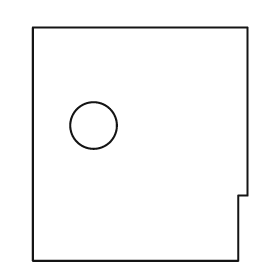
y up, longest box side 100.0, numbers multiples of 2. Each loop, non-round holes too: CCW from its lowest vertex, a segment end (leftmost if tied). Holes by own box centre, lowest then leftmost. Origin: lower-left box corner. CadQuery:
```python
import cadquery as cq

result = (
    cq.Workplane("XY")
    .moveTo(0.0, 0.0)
    .lineTo(88.0, 0.0)
    .lineTo(88.0, 28.0)
    .lineTo(92.0, 28.0)
    .lineTo(92.0, 100.0)
    .lineTo(0.0, 100.0)
    .close()
    .moveTo(26.0, 58.0)
    .circle(10.0)
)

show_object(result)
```